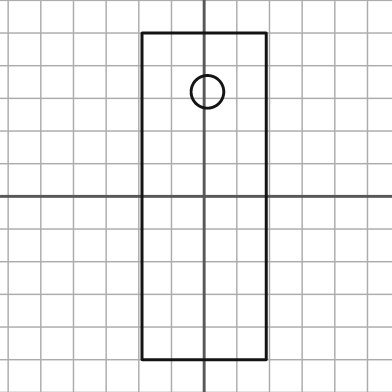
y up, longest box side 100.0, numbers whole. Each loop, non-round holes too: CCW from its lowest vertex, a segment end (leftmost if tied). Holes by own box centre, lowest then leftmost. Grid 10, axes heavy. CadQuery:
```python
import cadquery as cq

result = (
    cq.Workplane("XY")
    .moveTo(-19.0, -50.0)
    .lineTo(19.0, -50.0)
    .lineTo(19.0, 50.0)
    .lineTo(-19.0, 50.0)
    .close()
    .moveTo(1.0, 32.0)
    .circle(5.0)
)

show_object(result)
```